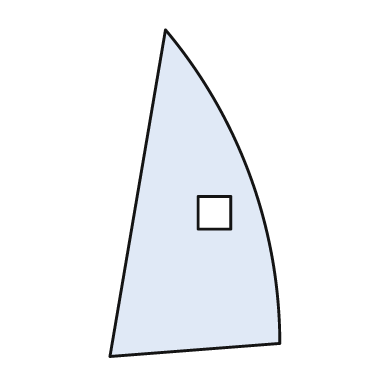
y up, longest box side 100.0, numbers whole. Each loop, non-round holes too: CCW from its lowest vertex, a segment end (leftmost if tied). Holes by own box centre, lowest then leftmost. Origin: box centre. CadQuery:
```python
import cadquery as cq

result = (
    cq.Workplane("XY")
    .moveTo(-26.0, -50.0)
    .lineTo(26.0, -46.0)
    .threePointArc((17.0, 5.0), (-9.0, 50.0))
    .close()
    .moveTo(1.0, -11.0)
    .lineTo(11.0, -11.0)
    .lineTo(11.0, -1.0)
    .lineTo(1.0, -1.0)
    .close()
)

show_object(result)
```